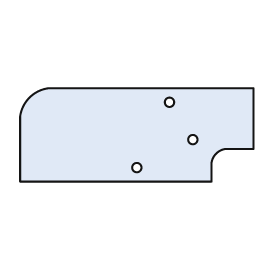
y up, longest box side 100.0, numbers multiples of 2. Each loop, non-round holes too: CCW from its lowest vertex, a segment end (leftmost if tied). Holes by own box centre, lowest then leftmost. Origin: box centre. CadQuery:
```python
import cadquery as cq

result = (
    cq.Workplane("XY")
    .moveTo(-50.0, -20.0)
    .lineTo(32.0, -20.0)
    .lineTo(32.0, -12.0)
    .threePointArc((34.0, -8.0), (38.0, -6.0))
    .lineTo(50.0, -6.0)
    .lineTo(50.0, 20.0)
    .lineTo(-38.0, 20.0)
    .threePointArc((-46.0, 16.0), (-50.0, 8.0))
    .close()
    .moveTo(0.0, -14.0)
    .circle(2.0)
    .moveTo(24.0, -2.0)
    .circle(2.0)
    .moveTo(14.0, 14.0)
    .circle(2.0)
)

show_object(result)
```